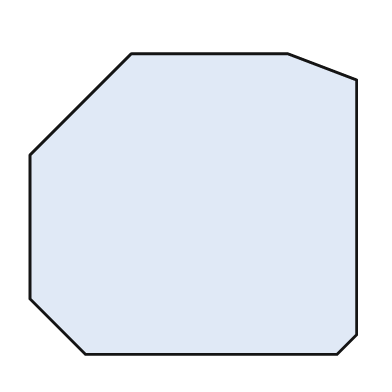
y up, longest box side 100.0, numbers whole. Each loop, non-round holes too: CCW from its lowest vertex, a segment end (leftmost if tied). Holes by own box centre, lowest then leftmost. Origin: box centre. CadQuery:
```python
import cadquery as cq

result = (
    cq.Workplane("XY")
    .moveTo(-33.0, -46.0)
    .lineTo(44.0, -46.0)
    .lineTo(50.0, -40.0)
    .lineTo(50.0, 38.0)
    .lineTo(29.0, 46.0)
    .lineTo(-19.0, 46.0)
    .lineTo(-50.0, 15.0)
    .lineTo(-50.0, -29.0)
    .close()
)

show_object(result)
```